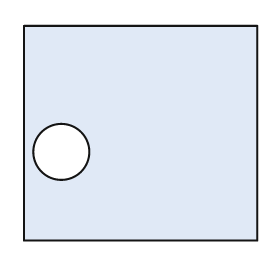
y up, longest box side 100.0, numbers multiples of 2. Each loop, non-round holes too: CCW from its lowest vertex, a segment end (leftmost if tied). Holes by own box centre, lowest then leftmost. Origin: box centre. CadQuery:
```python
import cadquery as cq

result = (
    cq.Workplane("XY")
    .moveTo(-50.0, -46.0)
    .lineTo(50.0, -46.0)
    .lineTo(50.0, 46.0)
    .lineTo(-50.0, 46.0)
    .close()
    .moveTo(-34.0, -8.0)
    .circle(12.0)
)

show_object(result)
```